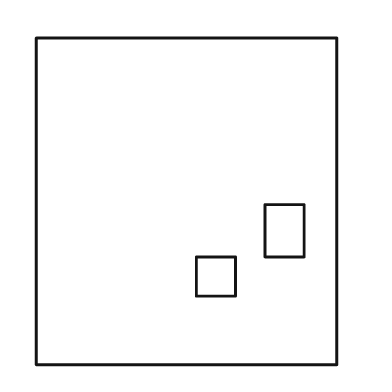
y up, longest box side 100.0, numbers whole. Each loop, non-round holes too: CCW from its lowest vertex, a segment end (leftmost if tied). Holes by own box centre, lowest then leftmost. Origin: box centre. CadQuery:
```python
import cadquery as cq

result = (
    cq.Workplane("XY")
    .moveTo(-46.0, -50.0)
    .lineTo(46.0, -50.0)
    .lineTo(46.0, 50.0)
    .lineTo(-46.0, 50.0)
    .close()
    .moveTo(3.0, -29.0)
    .lineTo(15.0, -29.0)
    .lineTo(15.0, -17.0)
    .lineTo(3.0, -17.0)
    .close()
    .moveTo(24.0, -17.0)
    .lineTo(36.0, -17.0)
    .lineTo(36.0, -1.0)
    .lineTo(24.0, -1.0)
    .close()
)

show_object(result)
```